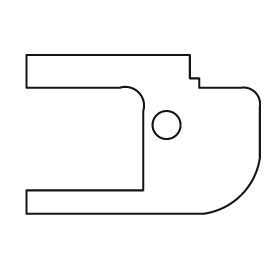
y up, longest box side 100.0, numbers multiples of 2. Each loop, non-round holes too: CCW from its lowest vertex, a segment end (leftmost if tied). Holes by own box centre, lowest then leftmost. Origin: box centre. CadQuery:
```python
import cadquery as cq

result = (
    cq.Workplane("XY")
    .moveTo(-50.0, -34.0)
    .lineTo(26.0, -34.0)
    .threePointArc((42.0, -26.0), (50.0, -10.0))
    .lineTo(50.0, 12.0)
    .threePointArc((48.0, 18.0), (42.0, 20.0))
    .lineTo(24.0, 20.0)
    .lineTo(24.0, 24.0)
    .lineTo(20.0, 24.0)
    .lineTo(20.0, 34.0)
    .lineTo(-50.0, 34.0)
    .lineTo(-50.0, 20.0)
    .lineTo(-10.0, 20.0)
    .threePointArc((-2.0, 18.0), (0.0, 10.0))
    .lineTo(0.0, -24.0)
    .lineTo(-50.0, -24.0)
    .close()
    .moveTo(10.0, 4.0)
    .circle(6.0)
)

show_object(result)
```